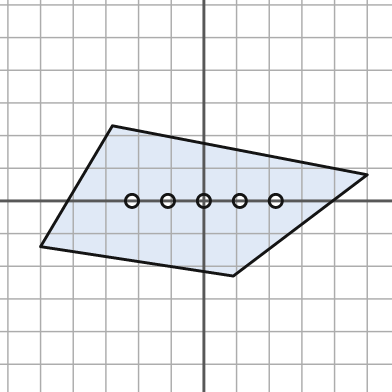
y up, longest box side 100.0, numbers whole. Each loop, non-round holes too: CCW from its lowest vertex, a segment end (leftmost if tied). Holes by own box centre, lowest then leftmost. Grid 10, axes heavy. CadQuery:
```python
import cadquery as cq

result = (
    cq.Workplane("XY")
    .moveTo(9.0, -23.0)
    .lineTo(50.0, 8.0)
    .lineTo(-28.0, 23.0)
    .lineTo(-50.0, -14.0)
    .close()
    .moveTo(-22.0, 0.0)
    .circle(2.0)
    .moveTo(-11.0, 0.0)
    .circle(2.0)
    .moveTo(0.0, 0.0)
    .circle(2.0)
    .moveTo(11.0, 0.0)
    .circle(2.0)
    .moveTo(22.0, 0.0)
    .circle(2.0)
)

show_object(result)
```